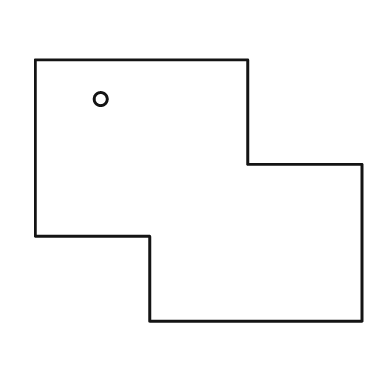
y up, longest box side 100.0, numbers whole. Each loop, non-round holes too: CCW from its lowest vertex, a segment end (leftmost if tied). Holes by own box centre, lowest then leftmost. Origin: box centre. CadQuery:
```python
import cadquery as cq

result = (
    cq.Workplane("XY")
    .moveTo(-15.0, -40.0)
    .lineTo(50.0, -40.0)
    .lineTo(50.0, 8.0)
    .lineTo(15.0, 8.0)
    .lineTo(15.0, 40.0)
    .lineTo(-50.0, 40.0)
    .lineTo(-50.0, -14.0)
    .lineTo(-15.0, -14.0)
    .close()
    .moveTo(-30.0, 28.0)
    .circle(2.0)
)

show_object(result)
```